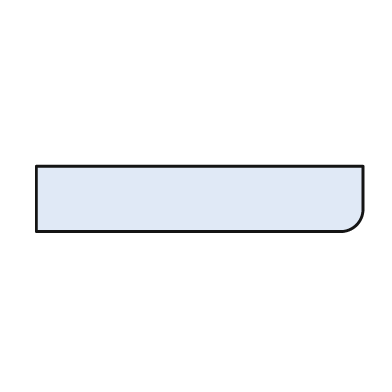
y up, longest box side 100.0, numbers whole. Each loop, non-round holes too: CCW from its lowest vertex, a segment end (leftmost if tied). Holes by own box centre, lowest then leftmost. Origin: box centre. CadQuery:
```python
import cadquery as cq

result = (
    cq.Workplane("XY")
    .moveTo(-50.0, -10.0)
    .lineTo(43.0, -10.0)
    .threePointArc((48.0, -8.0), (50.0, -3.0))
    .lineTo(50.0, 10.0)
    .lineTo(-50.0, 10.0)
    .close()
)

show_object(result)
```